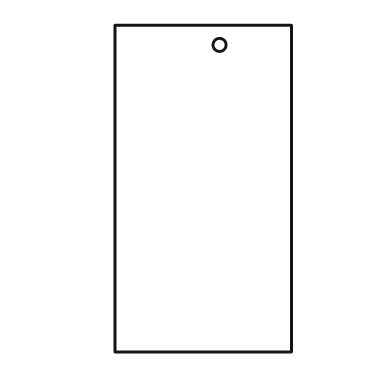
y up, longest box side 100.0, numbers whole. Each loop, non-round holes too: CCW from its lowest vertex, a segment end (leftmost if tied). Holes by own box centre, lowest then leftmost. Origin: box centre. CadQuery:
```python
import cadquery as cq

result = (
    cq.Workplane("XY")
    .moveTo(-27.0, -50.0)
    .lineTo(27.0, -50.0)
    .lineTo(27.0, 50.0)
    .lineTo(-27.0, 50.0)
    .close()
    .moveTo(5.0, 44.0)
    .circle(2.0)
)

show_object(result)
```